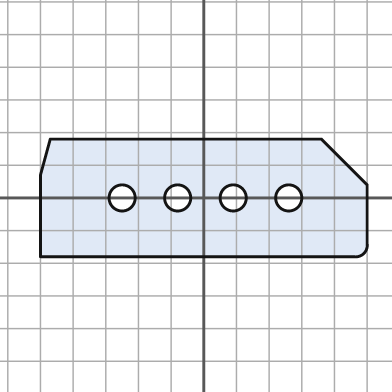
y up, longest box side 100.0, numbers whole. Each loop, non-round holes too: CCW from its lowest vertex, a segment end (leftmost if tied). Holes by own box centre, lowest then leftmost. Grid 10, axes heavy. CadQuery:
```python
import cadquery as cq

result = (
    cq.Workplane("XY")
    .moveTo(-50.0, -18.0)
    .lineTo(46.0, -18.0)
    .threePointArc((49.0, -17.0), (50.0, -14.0))
    .lineTo(50.0, 4.0)
    .lineTo(36.0, 18.0)
    .lineTo(-47.0, 18.0)
    .lineTo(-50.0, 7.0)
    .close()
    .moveTo(-25.0, 0.0)
    .circle(4.0)
    .moveTo(-8.0, 0.0)
    .circle(4.0)
    .moveTo(9.0, 0.0)
    .circle(4.0)
    .moveTo(26.0, 0.0)
    .circle(4.0)
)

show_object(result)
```